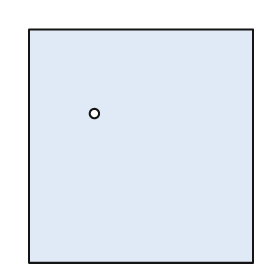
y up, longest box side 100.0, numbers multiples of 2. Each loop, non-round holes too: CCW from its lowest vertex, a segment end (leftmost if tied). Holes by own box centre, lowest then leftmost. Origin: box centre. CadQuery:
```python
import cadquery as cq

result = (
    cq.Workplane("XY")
    .moveTo(-48.0, -50.0)
    .lineTo(48.0, -50.0)
    .lineTo(48.0, 50.0)
    .lineTo(-48.0, 50.0)
    .close()
    .moveTo(-20.0, 14.0)
    .circle(2.0)
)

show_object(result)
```